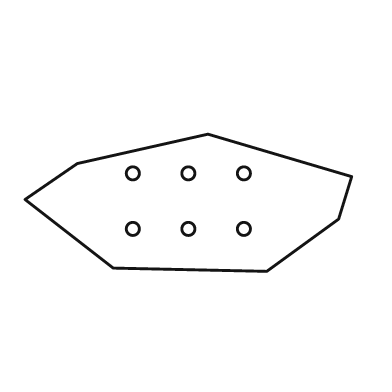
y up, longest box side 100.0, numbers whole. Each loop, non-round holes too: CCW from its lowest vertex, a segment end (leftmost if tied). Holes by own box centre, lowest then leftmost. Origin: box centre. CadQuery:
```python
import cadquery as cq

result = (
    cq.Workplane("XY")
    .moveTo(24.0, -21.0)
    .lineTo(46.0, -5.0)
    .lineTo(50.0, 8.0)
    .lineTo(6.0, 21.0)
    .lineTo(-34.0, 12.0)
    .lineTo(-50.0, 1.0)
    .lineTo(-23.0, -20.0)
    .close()
    .moveTo(-17.0, -8.0)
    .circle(2.0)
    .moveTo(0.0, -8.0)
    .circle(2.0)
    .moveTo(17.0, -8.0)
    .circle(2.0)
    .moveTo(-17.0, 9.0)
    .circle(2.0)
    .moveTo(0.0, 9.0)
    .circle(2.0)
    .moveTo(17.0, 9.0)
    .circle(2.0)
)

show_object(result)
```